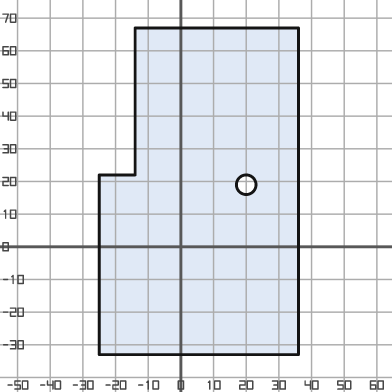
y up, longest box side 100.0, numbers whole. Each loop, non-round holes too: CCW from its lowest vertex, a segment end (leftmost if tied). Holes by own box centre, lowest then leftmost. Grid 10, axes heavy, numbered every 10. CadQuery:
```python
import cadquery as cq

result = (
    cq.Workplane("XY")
    .moveTo(-25.0, -33.0)
    .lineTo(36.0, -33.0)
    .lineTo(36.0, 67.0)
    .lineTo(-14.0, 67.0)
    .lineTo(-14.0, 22.0)
    .lineTo(-25.0, 22.0)
    .close()
    .moveTo(20.0, 19.0)
    .circle(3.0)
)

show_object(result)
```